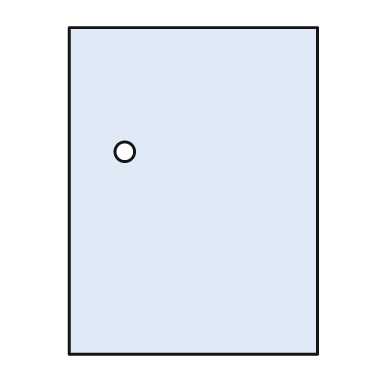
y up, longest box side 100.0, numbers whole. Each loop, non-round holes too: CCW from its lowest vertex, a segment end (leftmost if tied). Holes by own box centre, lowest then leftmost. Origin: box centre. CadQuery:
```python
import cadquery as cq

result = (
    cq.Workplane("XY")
    .moveTo(-38.0, -50.0)
    .lineTo(38.0, -50.0)
    .lineTo(38.0, 50.0)
    .lineTo(-38.0, 50.0)
    .close()
    .moveTo(-21.0, 12.0)
    .circle(3.0)
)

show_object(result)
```